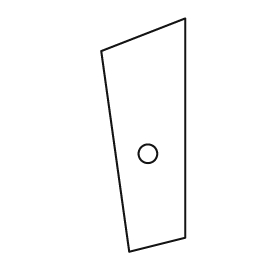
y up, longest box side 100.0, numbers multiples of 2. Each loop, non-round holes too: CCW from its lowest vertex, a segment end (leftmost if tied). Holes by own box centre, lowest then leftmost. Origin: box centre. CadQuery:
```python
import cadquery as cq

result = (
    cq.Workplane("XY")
    .moveTo(-6.0, -50.0)
    .lineTo(18.0, -44.0)
    .lineTo(18.0, 50.0)
    .lineTo(-18.0, 36.0)
    .close()
    .moveTo(2.0, -8.0)
    .circle(4.0)
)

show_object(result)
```